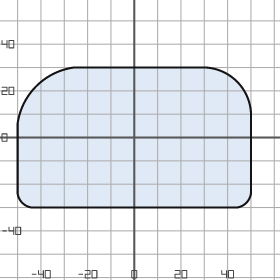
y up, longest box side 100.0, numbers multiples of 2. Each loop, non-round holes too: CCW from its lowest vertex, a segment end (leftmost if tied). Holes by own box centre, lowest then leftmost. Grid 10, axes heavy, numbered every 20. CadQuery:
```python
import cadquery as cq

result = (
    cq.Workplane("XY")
    .moveTo(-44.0, -30.0)
    .lineTo(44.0, -30.0)
    .threePointArc((48.0, -28.0), (50.0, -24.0))
    .lineTo(50.0, 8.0)
    .threePointArc((44.0, 24.0), (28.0, 30.0))
    .lineTo(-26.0, 30.0)
    .threePointArc((-42.0, 22.0), (-50.0, 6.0))
    .lineTo(-50.0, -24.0)
    .threePointArc((-48.0, -28.0), (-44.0, -30.0))
    .close()
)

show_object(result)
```